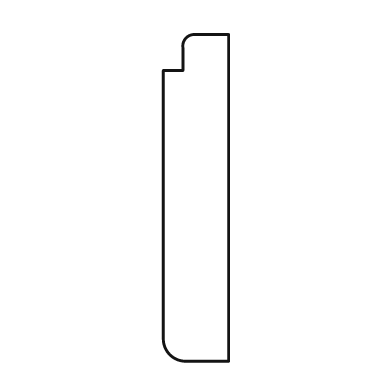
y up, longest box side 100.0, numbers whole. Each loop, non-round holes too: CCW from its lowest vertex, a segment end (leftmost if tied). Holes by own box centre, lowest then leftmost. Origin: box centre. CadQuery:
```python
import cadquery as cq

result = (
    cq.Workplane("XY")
    .moveTo(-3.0, -50.0)
    .lineTo(10.0, -50.0)
    .lineTo(10.0, 50.0)
    .lineTo(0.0, 50.0)
    .threePointArc((-3.0, 49.0), (-4.0, 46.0))
    .lineTo(-4.0, 39.0)
    .lineTo(-10.0, 39.0)
    .lineTo(-10.0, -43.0)
    .threePointArc((-8.0, -48.0), (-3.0, -50.0))
    .close()
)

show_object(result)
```